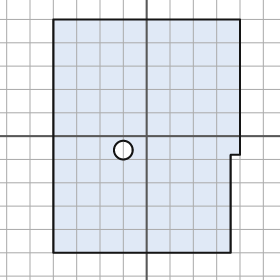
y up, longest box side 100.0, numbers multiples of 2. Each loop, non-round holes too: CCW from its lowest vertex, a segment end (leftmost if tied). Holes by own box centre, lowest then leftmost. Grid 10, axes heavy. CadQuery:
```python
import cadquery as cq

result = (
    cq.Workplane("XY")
    .moveTo(-40.0, -50.0)
    .lineTo(36.0, -50.0)
    .lineTo(36.0, -8.0)
    .lineTo(40.0, -8.0)
    .lineTo(40.0, 50.0)
    .lineTo(-40.0, 50.0)
    .close()
    .moveTo(-10.0, -6.0)
    .circle(4.0)
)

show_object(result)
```